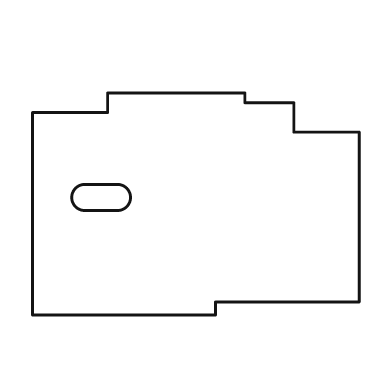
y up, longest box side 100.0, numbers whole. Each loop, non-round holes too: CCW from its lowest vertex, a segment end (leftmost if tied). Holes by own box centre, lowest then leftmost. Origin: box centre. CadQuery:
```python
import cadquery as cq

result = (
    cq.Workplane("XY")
    .moveTo(-50.0, -34.0)
    .lineTo(6.0, -34.0)
    .lineTo(6.0, -30.0)
    .lineTo(50.0, -30.0)
    .lineTo(50.0, 22.0)
    .lineTo(30.0, 22.0)
    .lineTo(30.0, 31.0)
    .lineTo(15.0, 31.0)
    .lineTo(15.0, 34.0)
    .lineTo(-27.0, 34.0)
    .lineTo(-27.0, 28.0)
    .lineTo(-50.0, 28.0)
    .close()
    .moveTo(-34.0, -2.0)
    .lineTo(-24.0, -2.0)
    .threePointArc((-20.0, 2.0), (-24.0, 6.0))
    .lineTo(-34.0, 6.0)
    .threePointArc((-38.0, 2.0), (-34.0, -2.0))
    .close()
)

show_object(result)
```